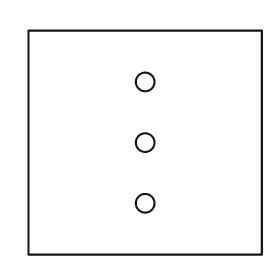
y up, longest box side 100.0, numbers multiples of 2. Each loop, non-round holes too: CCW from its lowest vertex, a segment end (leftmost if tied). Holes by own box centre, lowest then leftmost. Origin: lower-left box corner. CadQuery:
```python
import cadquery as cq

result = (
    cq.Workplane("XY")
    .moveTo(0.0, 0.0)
    .lineTo(100.0, 0.0)
    .lineTo(100.0, 96.0)
    .lineTo(0.0, 96.0)
    .close()
    .moveTo(50.0, 22.0)
    .circle(4.0)
    .moveTo(50.0, 48.0)
    .circle(4.0)
    .moveTo(50.0, 74.0)
    .circle(4.0)
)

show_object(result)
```